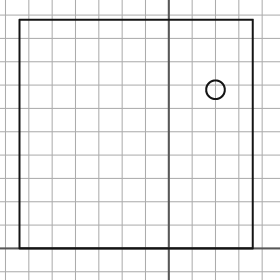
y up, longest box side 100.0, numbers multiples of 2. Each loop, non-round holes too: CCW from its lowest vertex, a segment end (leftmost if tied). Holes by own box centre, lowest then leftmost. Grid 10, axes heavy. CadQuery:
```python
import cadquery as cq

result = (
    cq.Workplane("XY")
    .moveTo(-64.0, 0.0)
    .lineTo(36.0, 0.0)
    .lineTo(36.0, 98.0)
    .lineTo(-64.0, 98.0)
    .close()
    .moveTo(20.0, 68.0)
    .circle(4.0)
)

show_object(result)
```